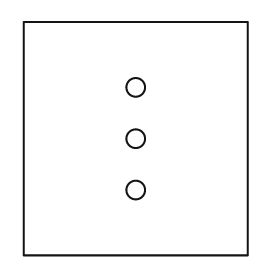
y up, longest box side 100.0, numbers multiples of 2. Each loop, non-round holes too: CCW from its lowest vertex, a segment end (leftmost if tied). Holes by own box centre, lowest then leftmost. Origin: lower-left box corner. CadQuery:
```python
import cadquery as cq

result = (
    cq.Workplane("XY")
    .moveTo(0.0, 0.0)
    .lineTo(96.0, 0.0)
    .lineTo(96.0, 100.0)
    .lineTo(0.0, 100.0)
    .close()
    .moveTo(48.0, 28.0)
    .circle(4.0)
    .moveTo(48.0, 50.0)
    .circle(4.0)
    .moveTo(48.0, 72.0)
    .circle(4.0)
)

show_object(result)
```